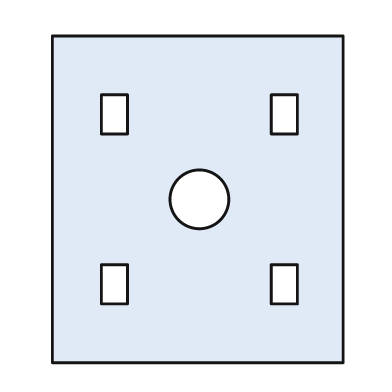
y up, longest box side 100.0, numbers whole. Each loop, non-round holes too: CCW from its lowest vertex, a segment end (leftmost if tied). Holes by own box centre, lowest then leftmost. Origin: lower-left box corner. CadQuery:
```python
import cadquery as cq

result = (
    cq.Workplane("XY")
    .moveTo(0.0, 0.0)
    .lineTo(89.0, 0.0)
    .lineTo(89.0, 100.0)
    .lineTo(0.0, 100.0)
    .close()
    .moveTo(15.0, 18.0)
    .lineTo(23.0, 18.0)
    .lineTo(23.0, 30.0)
    .lineTo(15.0, 30.0)
    .close()
    .moveTo(67.0, 18.0)
    .lineTo(75.0, 18.0)
    .lineTo(75.0, 30.0)
    .lineTo(67.0, 30.0)
    .close()
    .moveTo(45.0, 50.0)
    .circle(9.0)
    .moveTo(15.0, 70.0)
    .lineTo(23.0, 70.0)
    .lineTo(23.0, 82.0)
    .lineTo(15.0, 82.0)
    .close()
    .moveTo(67.0, 70.0)
    .lineTo(75.0, 70.0)
    .lineTo(75.0, 82.0)
    .lineTo(67.0, 82.0)
    .close()
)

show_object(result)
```